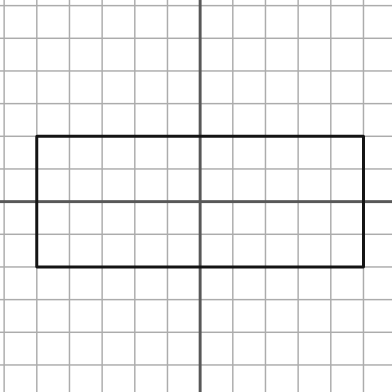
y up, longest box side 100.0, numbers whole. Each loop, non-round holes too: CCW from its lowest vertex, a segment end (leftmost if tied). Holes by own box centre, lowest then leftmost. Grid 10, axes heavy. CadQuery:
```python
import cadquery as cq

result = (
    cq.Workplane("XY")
    .moveTo(-50.0, -20.0)
    .lineTo(50.0, -20.0)
    .lineTo(50.0, 20.0)
    .lineTo(-50.0, 20.0)
    .close()
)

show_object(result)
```